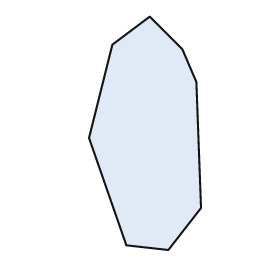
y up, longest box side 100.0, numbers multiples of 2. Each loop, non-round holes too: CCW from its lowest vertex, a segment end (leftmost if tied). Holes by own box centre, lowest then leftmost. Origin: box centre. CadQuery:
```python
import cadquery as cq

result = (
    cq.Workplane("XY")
    .moveTo(10.0, -50.0)
    .lineTo(24.0, -32.0)
    .lineTo(22.0, 22.0)
    .lineTo(16.0, 36.0)
    .lineTo(2.0, 50.0)
    .lineTo(-14.0, 38.0)
    .lineTo(-24.0, -2.0)
    .lineTo(-8.0, -48.0)
    .close()
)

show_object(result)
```